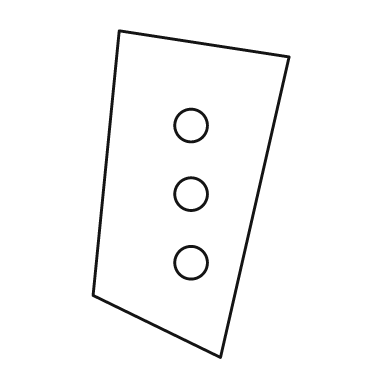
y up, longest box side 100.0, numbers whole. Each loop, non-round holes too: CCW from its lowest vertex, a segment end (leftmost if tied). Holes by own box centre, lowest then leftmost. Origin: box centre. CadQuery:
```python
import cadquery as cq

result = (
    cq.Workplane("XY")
    .moveTo(9.0, -50.0)
    .lineTo(30.0, 42.0)
    .lineTo(-22.0, 50.0)
    .lineTo(-30.0, -31.0)
    .close()
    .moveTo(0.0, -21.0)
    .circle(5.0)
    .moveTo(0.0, 0.0)
    .circle(5.0)
    .moveTo(0.0, 21.0)
    .circle(5.0)
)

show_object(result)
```